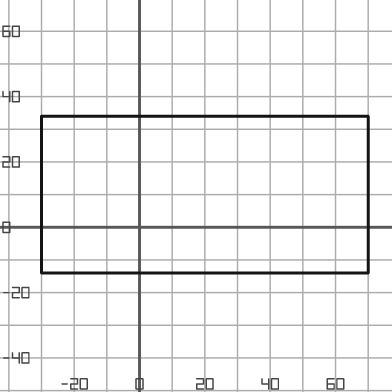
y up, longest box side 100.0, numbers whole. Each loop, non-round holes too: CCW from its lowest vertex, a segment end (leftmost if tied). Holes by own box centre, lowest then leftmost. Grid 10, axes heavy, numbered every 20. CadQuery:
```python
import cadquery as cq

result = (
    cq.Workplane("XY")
    .moveTo(-30.0, -14.0)
    .lineTo(70.0, -14.0)
    .lineTo(70.0, 34.0)
    .lineTo(-30.0, 34.0)
    .close()
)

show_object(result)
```